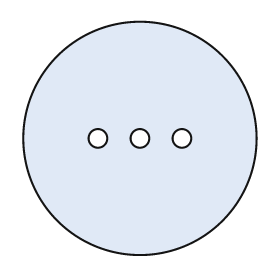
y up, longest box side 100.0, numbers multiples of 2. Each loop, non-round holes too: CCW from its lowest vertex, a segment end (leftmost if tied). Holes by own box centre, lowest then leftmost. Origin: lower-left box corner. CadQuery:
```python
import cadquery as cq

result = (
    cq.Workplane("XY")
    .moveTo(50.0, 50.0)
    .circle(50.0)
    .moveTo(32.0, 50.0)
    .circle(4.0)
    .moveTo(50.0, 50.0)
    .circle(4.0)
    .moveTo(68.0, 50.0)
    .circle(4.0)
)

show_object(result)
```